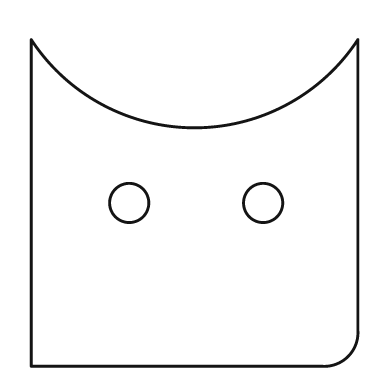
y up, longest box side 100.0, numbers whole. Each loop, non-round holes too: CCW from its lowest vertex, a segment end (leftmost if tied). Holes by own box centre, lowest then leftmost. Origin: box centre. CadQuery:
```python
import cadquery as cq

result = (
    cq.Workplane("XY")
    .moveTo(-50.0, -50.0)
    .lineTo(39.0, -50.0)
    .threePointArc((47.0, -47.0), (50.0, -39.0))
    .lineTo(50.0, 50.0)
    .threePointArc((0.0, 23.0), (-50.0, 50.0))
    .close()
    .moveTo(-20.0, 0.0)
    .circle(6.0)
    .moveTo(21.0, 0.0)
    .circle(6.0)
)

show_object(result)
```